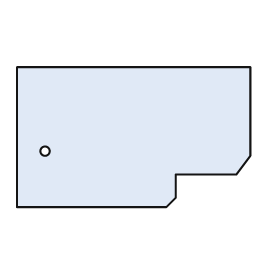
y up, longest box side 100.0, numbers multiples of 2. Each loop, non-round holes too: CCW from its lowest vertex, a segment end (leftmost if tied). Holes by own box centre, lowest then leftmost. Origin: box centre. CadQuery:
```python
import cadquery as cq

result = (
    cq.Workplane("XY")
    .moveTo(-50.0, -30.0)
    .lineTo(14.0, -30.0)
    .lineTo(18.0, -26.0)
    .lineTo(18.0, -16.0)
    .lineTo(44.0, -16.0)
    .lineTo(50.0, -8.0)
    .lineTo(50.0, 30.0)
    .lineTo(-50.0, 30.0)
    .close()
    .moveTo(-38.0, -6.0)
    .circle(2.0)
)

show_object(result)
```